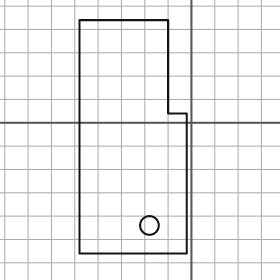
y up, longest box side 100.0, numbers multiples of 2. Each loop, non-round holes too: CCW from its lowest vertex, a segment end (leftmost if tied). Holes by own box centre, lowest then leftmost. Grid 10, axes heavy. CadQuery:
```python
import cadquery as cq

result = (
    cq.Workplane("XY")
    .moveTo(-48.0, -56.0)
    .lineTo(-2.0, -56.0)
    .lineTo(-2.0, 4.0)
    .lineTo(-10.0, 4.0)
    .lineTo(-10.0, 44.0)
    .lineTo(-48.0, 44.0)
    .close()
    .moveTo(-18.0, -44.0)
    .circle(4.0)
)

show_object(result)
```